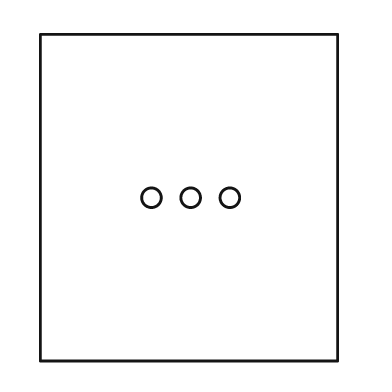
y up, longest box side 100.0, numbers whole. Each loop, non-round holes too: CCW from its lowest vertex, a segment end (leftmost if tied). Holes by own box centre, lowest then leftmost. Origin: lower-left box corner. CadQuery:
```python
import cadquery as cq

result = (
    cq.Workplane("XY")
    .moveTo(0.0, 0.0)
    .lineTo(91.0, 0.0)
    .lineTo(91.0, 100.0)
    .lineTo(0.0, 100.0)
    .close()
    .moveTo(34.0, 50.0)
    .circle(3.0)
    .moveTo(46.0, 50.0)
    .circle(3.0)
    .moveTo(58.0, 50.0)
    .circle(3.0)
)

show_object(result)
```